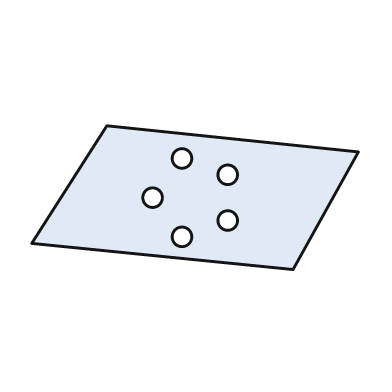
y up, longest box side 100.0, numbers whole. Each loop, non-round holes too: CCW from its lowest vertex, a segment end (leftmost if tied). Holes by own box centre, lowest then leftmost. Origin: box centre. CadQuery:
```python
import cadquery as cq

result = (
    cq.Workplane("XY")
    .moveTo(30.0, -22.0)
    .lineTo(50.0, 14.0)
    .lineTo(-27.0, 22.0)
    .lineTo(-50.0, -14.0)
    .close()
    .moveTo(-4.0, -12.0)
    .circle(3.0)
    .moveTo(10.0, -7.0)
    .circle(3.0)
    .moveTo(-13.0, 0.0)
    .circle(3.0)
    .moveTo(10.0, 7.0)
    .circle(3.0)
    .moveTo(-4.0, 12.0)
    .circle(3.0)
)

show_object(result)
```